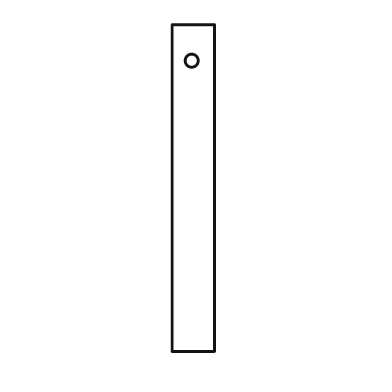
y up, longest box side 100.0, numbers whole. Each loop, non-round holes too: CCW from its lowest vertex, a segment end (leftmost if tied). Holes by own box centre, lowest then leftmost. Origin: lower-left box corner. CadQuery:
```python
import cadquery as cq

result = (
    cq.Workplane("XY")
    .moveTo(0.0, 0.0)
    .lineTo(13.0, 0.0)
    .lineTo(13.0, 100.0)
    .lineTo(0.0, 100.0)
    .close()
    .moveTo(6.0, 89.0)
    .circle(2.0)
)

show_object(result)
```